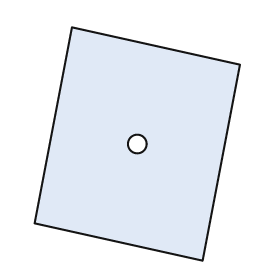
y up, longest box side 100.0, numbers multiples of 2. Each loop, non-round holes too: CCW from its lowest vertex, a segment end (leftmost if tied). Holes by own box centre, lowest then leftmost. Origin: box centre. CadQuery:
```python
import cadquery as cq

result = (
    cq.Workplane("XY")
    .moveTo(28.0, -50.0)
    .lineTo(44.0, 34.0)
    .lineTo(-28.0, 50.0)
    .lineTo(-44.0, -34.0)
    .close()
    .moveTo(0.0, 0.0)
    .circle(4.0)
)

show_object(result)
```